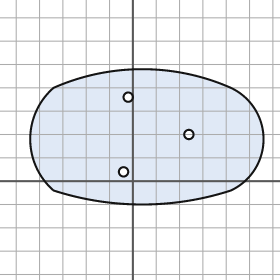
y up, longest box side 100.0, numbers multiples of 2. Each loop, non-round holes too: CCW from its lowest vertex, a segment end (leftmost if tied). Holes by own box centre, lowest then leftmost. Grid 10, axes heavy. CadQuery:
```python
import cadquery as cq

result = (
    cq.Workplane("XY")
    .moveTo(-34.0, -4.0)
    .threePointArc((4.0, -10.0), (42.0, -4.0))
    .threePointArc((56.0, 18.0), (42.0, 40.0))
    .threePointArc((4.0, 48.0), (-34.0, 40.0))
    .threePointArc((-44.0, 18.0), (-34.0, -4.0))
    .close()
    .moveTo(-4.0, 4.0)
    .circle(2.0)
    .moveTo(24.0, 20.0)
    .circle(2.0)
    .moveTo(-2.0, 36.0)
    .circle(2.0)
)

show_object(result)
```